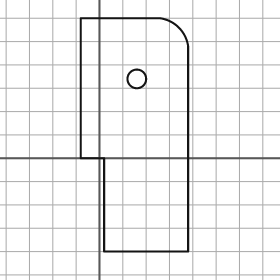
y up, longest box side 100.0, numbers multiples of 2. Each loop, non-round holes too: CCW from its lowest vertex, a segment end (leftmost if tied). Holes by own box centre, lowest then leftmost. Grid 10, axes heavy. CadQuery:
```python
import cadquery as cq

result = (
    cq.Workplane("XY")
    .moveTo(2.0, -40.0)
    .lineTo(38.0, -40.0)
    .lineTo(38.0, 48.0)
    .threePointArc((34.0, 56.0), (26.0, 60.0))
    .lineTo(-8.0, 60.0)
    .lineTo(-8.0, 0.0)
    .lineTo(2.0, 0.0)
    .close()
    .moveTo(16.0, 34.0)
    .circle(4.0)
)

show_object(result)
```